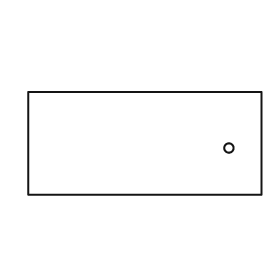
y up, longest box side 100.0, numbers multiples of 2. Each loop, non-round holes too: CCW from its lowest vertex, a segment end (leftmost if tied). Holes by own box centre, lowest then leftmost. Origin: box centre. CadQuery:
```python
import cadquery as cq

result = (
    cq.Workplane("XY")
    .moveTo(-50.0, -22.0)
    .lineTo(50.0, -22.0)
    .lineTo(50.0, 22.0)
    .lineTo(-50.0, 22.0)
    .close()
    .moveTo(36.0, -2.0)
    .circle(2.0)
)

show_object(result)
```